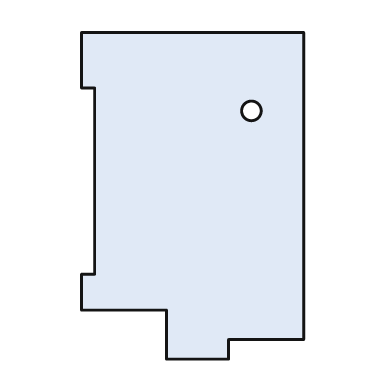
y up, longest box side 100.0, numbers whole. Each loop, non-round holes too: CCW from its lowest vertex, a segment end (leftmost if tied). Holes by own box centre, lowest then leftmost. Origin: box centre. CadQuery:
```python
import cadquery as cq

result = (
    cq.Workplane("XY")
    .moveTo(-8.0, -50.0)
    .lineTo(11.0, -50.0)
    .lineTo(11.0, -44.0)
    .lineTo(34.0, -44.0)
    .lineTo(34.0, 50.0)
    .lineTo(-34.0, 50.0)
    .lineTo(-34.0, 33.0)
    .lineTo(-30.0, 33.0)
    .lineTo(-30.0, -24.0)
    .lineTo(-34.0, -24.0)
    .lineTo(-34.0, -35.0)
    .lineTo(-8.0, -35.0)
    .close()
    .moveTo(18.0, 26.0)
    .circle(3.0)
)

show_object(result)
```